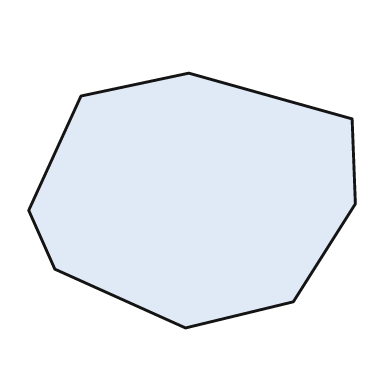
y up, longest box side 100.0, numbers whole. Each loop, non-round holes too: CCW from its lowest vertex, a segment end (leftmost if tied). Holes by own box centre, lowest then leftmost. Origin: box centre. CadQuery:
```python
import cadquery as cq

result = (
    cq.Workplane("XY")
    .moveTo(-2.0, -39.0)
    .lineTo(31.0, -31.0)
    .lineTo(50.0, -1.0)
    .lineTo(49.0, 25.0)
    .lineTo(-1.0, 39.0)
    .lineTo(-34.0, 32.0)
    .lineTo(-50.0, -3.0)
    .lineTo(-42.0, -21.0)
    .close()
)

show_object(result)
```